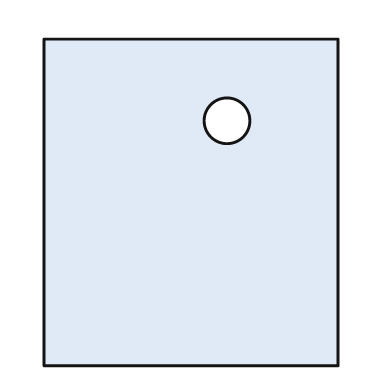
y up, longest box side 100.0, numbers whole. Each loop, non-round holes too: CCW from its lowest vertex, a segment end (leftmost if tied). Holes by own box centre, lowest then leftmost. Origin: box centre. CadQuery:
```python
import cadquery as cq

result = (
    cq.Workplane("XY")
    .moveTo(-45.0, -50.0)
    .lineTo(45.0, -50.0)
    .lineTo(45.0, 50.0)
    .lineTo(-45.0, 50.0)
    .close()
    .moveTo(11.0, 25.0)
    .circle(7.0)
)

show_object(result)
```